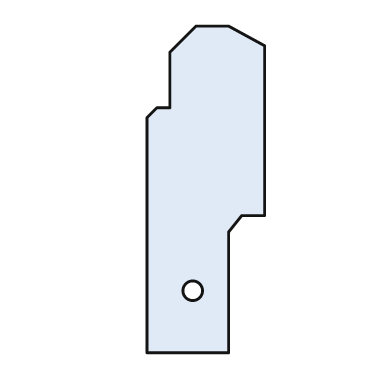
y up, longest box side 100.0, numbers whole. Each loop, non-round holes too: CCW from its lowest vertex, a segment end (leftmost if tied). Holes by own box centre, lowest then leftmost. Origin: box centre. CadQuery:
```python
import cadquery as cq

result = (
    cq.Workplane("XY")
    .moveTo(-18.0, -50.0)
    .lineTo(7.0, -50.0)
    .lineTo(7.0, -13.0)
    .lineTo(11.0, -8.0)
    .lineTo(18.0, -8.0)
    .lineTo(18.0, 44.0)
    .lineTo(7.0, 50.0)
    .lineTo(-3.0, 50.0)
    .lineTo(-11.0, 42.0)
    .lineTo(-11.0, 25.0)
    .lineTo(-15.0, 25.0)
    .lineTo(-18.0, 22.0)
    .close()
    .moveTo(-4.0, -31.0)
    .circle(3.0)
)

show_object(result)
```